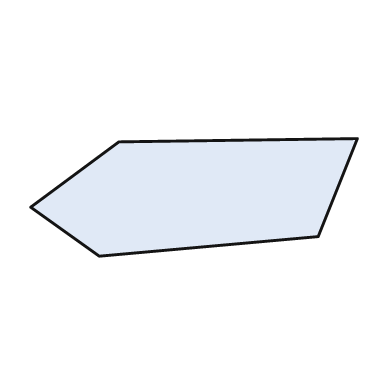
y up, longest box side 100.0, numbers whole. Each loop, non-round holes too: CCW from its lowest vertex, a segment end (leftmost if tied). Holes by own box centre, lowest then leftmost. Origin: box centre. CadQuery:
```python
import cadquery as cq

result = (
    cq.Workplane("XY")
    .moveTo(-29.0, -18.0)
    .lineTo(38.0, -12.0)
    .lineTo(50.0, 18.0)
    .lineTo(-23.0, 17.0)
    .lineTo(-50.0, -3.0)
    .close()
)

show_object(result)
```